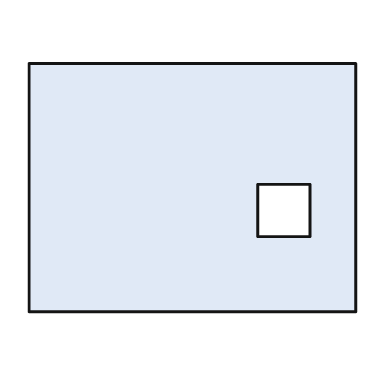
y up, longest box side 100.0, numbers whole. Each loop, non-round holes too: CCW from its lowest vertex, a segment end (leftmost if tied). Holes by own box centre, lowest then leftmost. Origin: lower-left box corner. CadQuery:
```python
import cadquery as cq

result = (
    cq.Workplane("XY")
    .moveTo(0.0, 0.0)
    .lineTo(100.0, 0.0)
    .lineTo(100.0, 76.0)
    .lineTo(0.0, 76.0)
    .close()
    .moveTo(70.0, 23.0)
    .lineTo(86.0, 23.0)
    .lineTo(86.0, 39.0)
    .lineTo(70.0, 39.0)
    .close()
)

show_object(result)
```